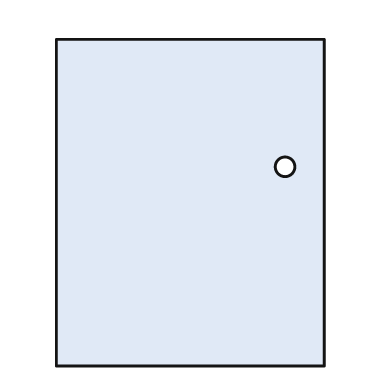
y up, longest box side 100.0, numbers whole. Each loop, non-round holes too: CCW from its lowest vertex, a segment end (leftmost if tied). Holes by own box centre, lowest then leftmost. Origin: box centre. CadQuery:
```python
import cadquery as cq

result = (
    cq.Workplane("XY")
    .moveTo(-41.0, -50.0)
    .lineTo(41.0, -50.0)
    .lineTo(41.0, 50.0)
    .lineTo(-41.0, 50.0)
    .close()
    .moveTo(29.0, 11.0)
    .circle(3.0)
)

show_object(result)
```